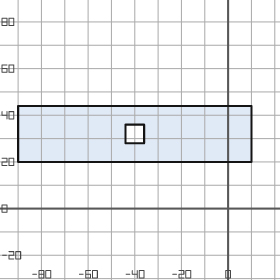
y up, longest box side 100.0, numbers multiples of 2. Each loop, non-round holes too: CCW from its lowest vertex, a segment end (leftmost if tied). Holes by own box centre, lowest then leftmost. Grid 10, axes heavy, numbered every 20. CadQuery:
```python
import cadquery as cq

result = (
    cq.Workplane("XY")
    .moveTo(-90.0, 20.0)
    .lineTo(10.0, 20.0)
    .lineTo(10.0, 44.0)
    .lineTo(-90.0, 44.0)
    .close()
    .moveTo(-44.0, 28.0)
    .lineTo(-36.0, 28.0)
    .lineTo(-36.0, 36.0)
    .lineTo(-44.0, 36.0)
    .close()
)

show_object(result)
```